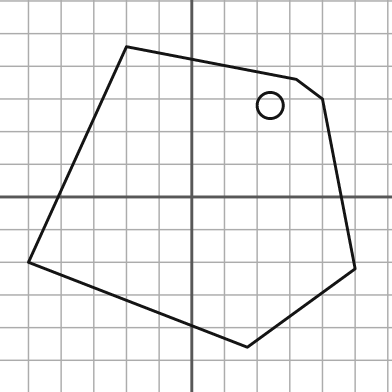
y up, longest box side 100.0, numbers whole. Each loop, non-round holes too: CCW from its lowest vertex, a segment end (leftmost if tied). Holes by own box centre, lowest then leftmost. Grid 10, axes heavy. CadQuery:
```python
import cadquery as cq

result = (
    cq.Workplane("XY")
    .moveTo(17.0, -46.0)
    .lineTo(50.0, -22.0)
    .lineTo(40.0, 30.0)
    .lineTo(32.0, 36.0)
    .lineTo(-20.0, 46.0)
    .lineTo(-50.0, -20.0)
    .close()
    .moveTo(24.0, 28.0)
    .circle(4.0)
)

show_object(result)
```